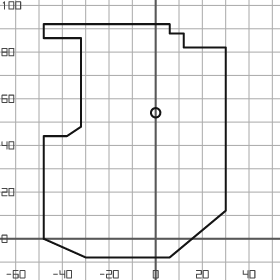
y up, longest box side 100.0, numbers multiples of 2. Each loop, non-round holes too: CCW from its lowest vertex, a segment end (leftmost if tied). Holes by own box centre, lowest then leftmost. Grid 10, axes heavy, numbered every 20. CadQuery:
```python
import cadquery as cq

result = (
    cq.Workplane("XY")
    .moveTo(-30.0, -8.0)
    .lineTo(6.0, -8.0)
    .lineTo(30.0, 12.0)
    .lineTo(30.0, 82.0)
    .lineTo(12.0, 82.0)
    .lineTo(12.0, 88.0)
    .lineTo(6.0, 88.0)
    .lineTo(6.0, 92.0)
    .lineTo(-48.0, 92.0)
    .lineTo(-48.0, 86.0)
    .lineTo(-32.0, 86.0)
    .lineTo(-32.0, 48.0)
    .lineTo(-38.0, 44.0)
    .lineTo(-48.0, 44.0)
    .lineTo(-48.0, 0.0)
    .close()
    .moveTo(0.0, 54.0)
    .circle(2.0)
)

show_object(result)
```